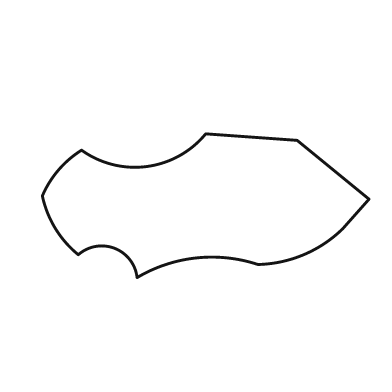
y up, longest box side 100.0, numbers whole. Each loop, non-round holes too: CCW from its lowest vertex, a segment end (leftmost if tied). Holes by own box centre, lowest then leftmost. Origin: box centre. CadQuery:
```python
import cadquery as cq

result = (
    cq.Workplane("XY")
    .moveTo(-21.0, -22.0)
    .threePointArc((-3.0, -16.0), (16.0, -18.0))
    .threePointArc((30.0, -15.0), (42.0, -7.0))
    .lineTo(50.0, 2.0)
    .lineTo(28.0, 20.0)
    .lineTo(0.0, 22.0)
    .threePointArc((-18.0, 12.0), (-38.0, 17.0))
    .threePointArc((-45.0, 11.0), (-50.0, 3.0))
    .threePointArc((-46.0, -7.0), (-39.0, -15.0))
    .threePointArc((-28.0, -13.0), (-21.0, -22.0))
    .close()
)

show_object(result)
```